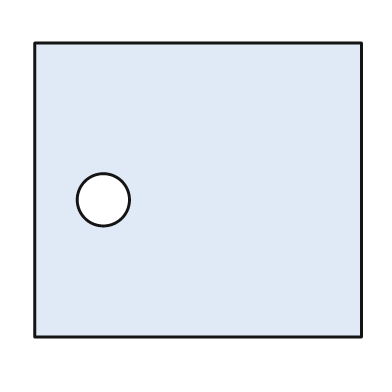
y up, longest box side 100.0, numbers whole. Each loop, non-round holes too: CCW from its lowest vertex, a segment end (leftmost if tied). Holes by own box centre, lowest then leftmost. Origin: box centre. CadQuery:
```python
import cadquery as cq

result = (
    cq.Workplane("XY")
    .moveTo(-50.0, -45.0)
    .lineTo(50.0, -45.0)
    .lineTo(50.0, 45.0)
    .lineTo(-50.0, 45.0)
    .close()
    .moveTo(-29.0, -3.0)
    .circle(8.0)
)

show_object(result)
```